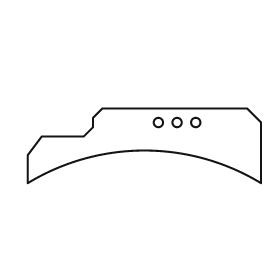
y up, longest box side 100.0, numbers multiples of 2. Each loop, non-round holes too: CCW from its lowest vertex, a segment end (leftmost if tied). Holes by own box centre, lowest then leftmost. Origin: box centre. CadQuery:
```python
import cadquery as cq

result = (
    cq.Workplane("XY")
    .moveTo(-50.0, -16.0)
    .threePointArc((0.0, -2.0), (50.0, -16.0))
    .lineTo(50.0, 10.0)
    .lineTo(44.0, 16.0)
    .lineTo(-18.0, 16.0)
    .lineTo(-22.0, 12.0)
    .lineTo(-22.0, 8.0)
    .lineTo(-26.0, 4.0)
    .lineTo(-44.0, 4.0)
    .lineTo(-50.0, -4.0)
    .close()
    .moveTo(6.0, 10.0)
    .circle(2.0)
    .moveTo(14.0, 10.0)
    .circle(2.0)
    .moveTo(22.0, 10.0)
    .circle(2.0)
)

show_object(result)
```